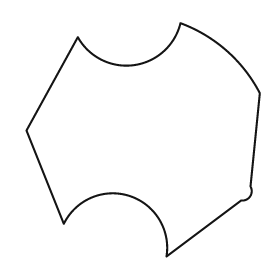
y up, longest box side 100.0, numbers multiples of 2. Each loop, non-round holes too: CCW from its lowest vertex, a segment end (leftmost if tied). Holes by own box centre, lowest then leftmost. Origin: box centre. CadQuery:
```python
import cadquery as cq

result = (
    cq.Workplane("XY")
    .moveTo(10.0, -50.0)
    .lineTo(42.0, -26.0)
    .threePointArc((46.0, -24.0), (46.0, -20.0))
    .lineTo(50.0, 20.0)
    .threePointArc((36.0, 38.0), (16.0, 50.0))
    .threePointArc((-4.0, 32.0), (-28.0, 44.0))
    .lineTo(-50.0, 4.0)
    .lineTo(-34.0, -36.0)
    .threePointArc((-6.0, -24.0), (10.0, -50.0))
    .close()
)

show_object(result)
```